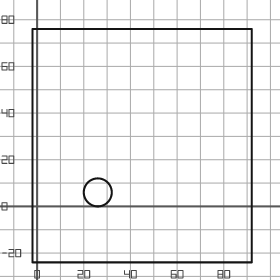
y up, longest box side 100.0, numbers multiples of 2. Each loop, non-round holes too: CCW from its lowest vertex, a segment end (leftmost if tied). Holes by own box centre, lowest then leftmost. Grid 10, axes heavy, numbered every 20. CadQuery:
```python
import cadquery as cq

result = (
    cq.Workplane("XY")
    .moveTo(-2.0, -24.0)
    .lineTo(92.0, -24.0)
    .lineTo(92.0, 76.0)
    .lineTo(-2.0, 76.0)
    .close()
    .moveTo(26.0, 6.0)
    .circle(6.0)
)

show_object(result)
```